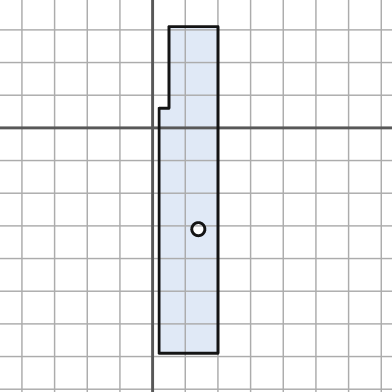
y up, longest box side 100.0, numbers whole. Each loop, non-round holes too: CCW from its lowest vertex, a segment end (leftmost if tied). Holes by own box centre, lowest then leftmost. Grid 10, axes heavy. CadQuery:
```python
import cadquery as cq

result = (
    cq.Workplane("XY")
    .moveTo(2.0, -69.0)
    .lineTo(20.0, -69.0)
    .lineTo(20.0, 31.0)
    .lineTo(5.0, 31.0)
    .lineTo(5.0, 6.0)
    .lineTo(2.0, 6.0)
    .close()
    .moveTo(14.0, -31.0)
    .circle(2.0)
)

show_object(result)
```